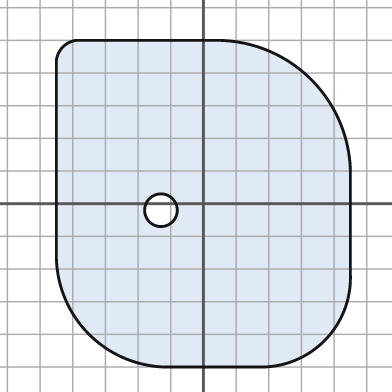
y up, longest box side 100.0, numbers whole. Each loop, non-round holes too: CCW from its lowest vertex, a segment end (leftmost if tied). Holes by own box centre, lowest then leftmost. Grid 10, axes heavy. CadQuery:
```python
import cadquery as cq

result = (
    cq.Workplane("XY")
    .moveTo(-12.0, -50.0)
    .lineTo(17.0, -50.0)
    .threePointArc((37.0, -42.0), (45.0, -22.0))
    .lineTo(45.0, 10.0)
    .threePointArc((33.0, 38.0), (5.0, 50.0))
    .lineTo(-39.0, 50.0)
    .threePointArc((-43.0, 48.0), (-45.0, 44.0))
    .lineTo(-45.0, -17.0)
    .threePointArc((-35.0, -40.0), (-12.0, -50.0))
    .close()
    .moveTo(-13.0, -2.0)
    .circle(5.0)
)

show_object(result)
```